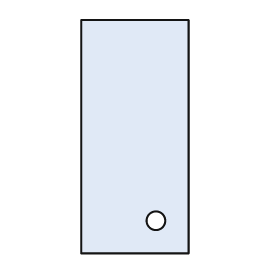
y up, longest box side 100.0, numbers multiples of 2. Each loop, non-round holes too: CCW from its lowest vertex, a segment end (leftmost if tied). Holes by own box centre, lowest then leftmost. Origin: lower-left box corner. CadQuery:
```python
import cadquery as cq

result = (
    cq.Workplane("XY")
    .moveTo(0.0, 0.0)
    .lineTo(46.0, 0.0)
    .lineTo(46.0, 100.0)
    .lineTo(0.0, 100.0)
    .close()
    .moveTo(32.0, 14.0)
    .circle(4.0)
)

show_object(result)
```